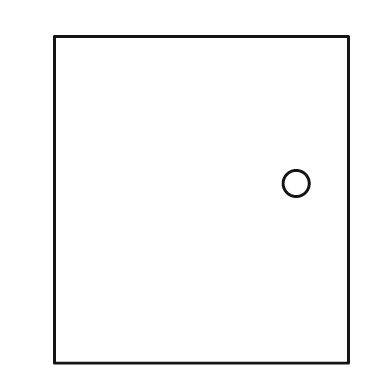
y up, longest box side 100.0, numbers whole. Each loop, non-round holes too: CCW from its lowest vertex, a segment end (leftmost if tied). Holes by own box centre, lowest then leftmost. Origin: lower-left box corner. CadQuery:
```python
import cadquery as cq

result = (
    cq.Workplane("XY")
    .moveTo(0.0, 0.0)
    .lineTo(90.0, 0.0)
    .lineTo(90.0, 100.0)
    .lineTo(0.0, 100.0)
    .close()
    .moveTo(74.0, 55.0)
    .circle(4.0)
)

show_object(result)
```